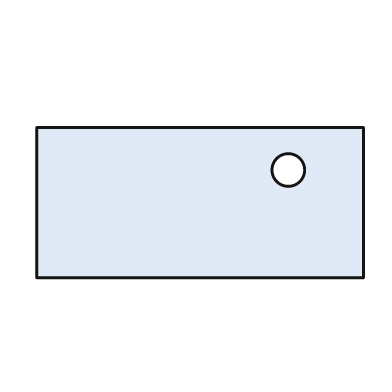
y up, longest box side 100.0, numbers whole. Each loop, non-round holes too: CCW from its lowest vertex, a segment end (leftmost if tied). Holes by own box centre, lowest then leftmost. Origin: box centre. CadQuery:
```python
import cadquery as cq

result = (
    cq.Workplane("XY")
    .moveTo(-50.0, -23.0)
    .lineTo(50.0, -23.0)
    .lineTo(50.0, 23.0)
    .lineTo(-50.0, 23.0)
    .close()
    .moveTo(27.0, 10.0)
    .circle(5.0)
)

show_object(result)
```